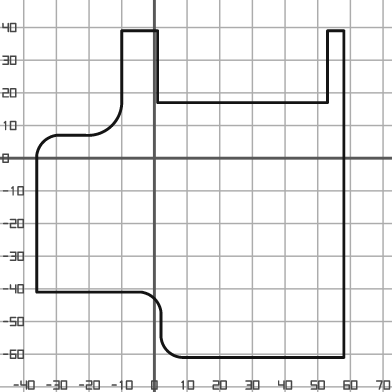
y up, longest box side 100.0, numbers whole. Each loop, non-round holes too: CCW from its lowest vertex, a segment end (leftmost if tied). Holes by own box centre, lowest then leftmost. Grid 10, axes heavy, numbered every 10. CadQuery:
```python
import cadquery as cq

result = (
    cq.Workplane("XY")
    .moveTo(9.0, -61.0)
    .lineTo(58.0, -61.0)
    .lineTo(58.0, 39.0)
    .lineTo(53.0, 39.0)
    .lineTo(53.0, 17.0)
    .lineTo(1.0, 17.0)
    .lineTo(1.0, 39.0)
    .lineTo(-10.0, 39.0)
    .lineTo(-10.0, 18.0)
    .threePointArc((-13.0, 10.0), (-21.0, 7.0))
    .lineTo(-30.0, 7.0)
    .threePointArc((-34.0, 5.0), (-36.0, 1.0))
    .lineTo(-36.0, -41.0)
    .lineTo(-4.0, -41.0)
    .threePointArc((0.0, -43.0), (2.0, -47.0))
    .lineTo(2.0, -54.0)
    .threePointArc((4.0, -59.0), (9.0, -61.0))
    .close()
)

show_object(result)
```